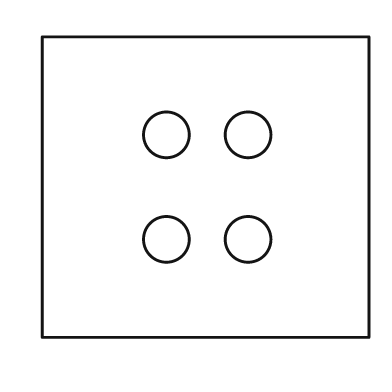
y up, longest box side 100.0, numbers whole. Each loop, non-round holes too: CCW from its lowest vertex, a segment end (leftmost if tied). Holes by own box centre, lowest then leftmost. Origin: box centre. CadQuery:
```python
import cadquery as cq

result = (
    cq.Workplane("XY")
    .moveTo(-50.0, -46.0)
    .lineTo(50.0, -46.0)
    .lineTo(50.0, 46.0)
    .lineTo(-50.0, 46.0)
    .close()
    .moveTo(-12.0, -16.0)
    .circle(7.0)
    .moveTo(13.0, -16.0)
    .circle(7.0)
    .moveTo(-12.0, 16.0)
    .circle(7.0)
    .moveTo(13.0, 16.0)
    .circle(7.0)
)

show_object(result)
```